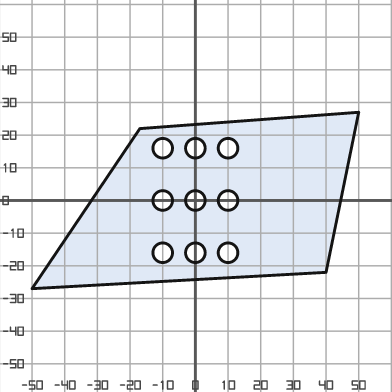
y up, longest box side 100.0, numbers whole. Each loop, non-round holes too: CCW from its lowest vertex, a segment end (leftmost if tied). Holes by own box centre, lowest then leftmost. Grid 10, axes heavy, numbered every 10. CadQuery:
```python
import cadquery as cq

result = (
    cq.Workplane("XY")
    .moveTo(-50.0, -27.0)
    .lineTo(40.0, -22.0)
    .lineTo(50.0, 27.0)
    .lineTo(-17.0, 22.0)
    .close()
    .moveTo(-10.0, -16.0)
    .circle(3.0)
    .moveTo(0.0, -16.0)
    .circle(3.0)
    .moveTo(10.0, -16.0)
    .circle(3.0)
    .moveTo(-10.0, 0.0)
    .circle(3.0)
    .moveTo(0.0, 0.0)
    .circle(3.0)
    .moveTo(10.0, 0.0)
    .circle(3.0)
    .moveTo(-10.0, 16.0)
    .circle(3.0)
    .moveTo(0.0, 16.0)
    .circle(3.0)
    .moveTo(10.0, 16.0)
    .circle(3.0)
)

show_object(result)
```